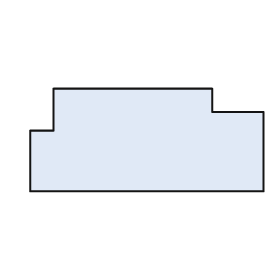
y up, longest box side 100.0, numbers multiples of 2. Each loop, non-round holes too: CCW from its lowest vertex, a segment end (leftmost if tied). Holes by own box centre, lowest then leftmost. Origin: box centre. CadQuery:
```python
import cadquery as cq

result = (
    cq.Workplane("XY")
    .moveTo(-50.0, -22.0)
    .lineTo(50.0, -22.0)
    .lineTo(50.0, 12.0)
    .lineTo(28.0, 12.0)
    .lineTo(28.0, 22.0)
    .lineTo(-40.0, 22.0)
    .lineTo(-40.0, 4.0)
    .lineTo(-50.0, 4.0)
    .close()
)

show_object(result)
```